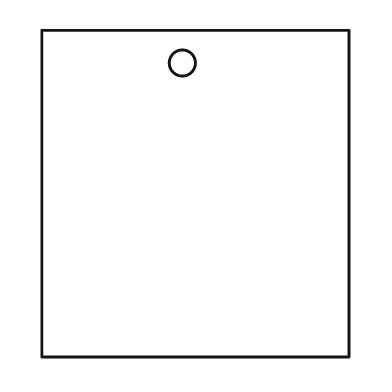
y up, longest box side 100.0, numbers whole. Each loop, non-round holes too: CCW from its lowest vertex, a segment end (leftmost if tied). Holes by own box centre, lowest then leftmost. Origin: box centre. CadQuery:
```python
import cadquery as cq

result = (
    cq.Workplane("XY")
    .moveTo(-47.0, -50.0)
    .lineTo(47.0, -50.0)
    .lineTo(47.0, 50.0)
    .lineTo(-47.0, 50.0)
    .close()
    .moveTo(-4.0, 40.0)
    .circle(4.0)
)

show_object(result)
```